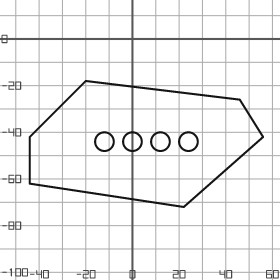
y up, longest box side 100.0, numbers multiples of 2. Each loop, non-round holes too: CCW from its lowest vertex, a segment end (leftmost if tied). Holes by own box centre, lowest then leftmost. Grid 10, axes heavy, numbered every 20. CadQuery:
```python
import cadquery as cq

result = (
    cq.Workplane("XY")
    .moveTo(22.0, -72.0)
    .lineTo(56.0, -42.0)
    .lineTo(46.0, -26.0)
    .lineTo(-20.0, -18.0)
    .lineTo(-44.0, -42.0)
    .lineTo(-44.0, -62.0)
    .close()
    .moveTo(-12.0, -44.0)
    .circle(4.0)
    .moveTo(0.0, -44.0)
    .circle(4.0)
    .moveTo(12.0, -44.0)
    .circle(4.0)
    .moveTo(24.0, -44.0)
    .circle(4.0)
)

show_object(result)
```